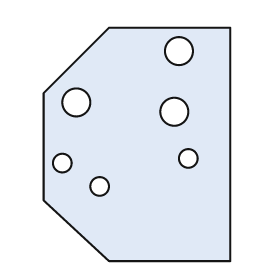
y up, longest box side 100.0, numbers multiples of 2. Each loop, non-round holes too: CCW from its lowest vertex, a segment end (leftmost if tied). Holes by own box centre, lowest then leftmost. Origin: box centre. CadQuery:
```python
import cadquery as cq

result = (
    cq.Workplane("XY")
    .moveTo(-12.0, -50.0)
    .lineTo(40.0, -50.0)
    .lineTo(40.0, 50.0)
    .lineTo(-12.0, 50.0)
    .lineTo(-40.0, 22.0)
    .lineTo(-40.0, -24.0)
    .close()
    .moveTo(-16.0, -18.0)
    .circle(4.0)
    .moveTo(-32.0, -8.0)
    .circle(4.0)
    .moveTo(22.0, -6.0)
    .circle(4.0)
    .moveTo(16.0, 14.0)
    .circle(6.0)
    .moveTo(-26.0, 18.0)
    .circle(6.0)
    .moveTo(18.0, 40.0)
    .circle(6.0)
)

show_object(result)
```